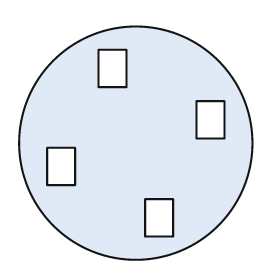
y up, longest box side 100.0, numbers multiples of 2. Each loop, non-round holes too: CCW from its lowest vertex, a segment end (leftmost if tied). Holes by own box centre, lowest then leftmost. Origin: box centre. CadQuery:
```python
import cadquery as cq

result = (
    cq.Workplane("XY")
    .moveTo(0.0, 0.0)
    .circle(50.0)
    .moveTo(4.0, -40.0)
    .lineTo(16.0, -40.0)
    .lineTo(16.0, -24.0)
    .lineTo(4.0, -24.0)
    .close()
    .moveTo(-38.0, -18.0)
    .lineTo(-26.0, -18.0)
    .lineTo(-26.0, -2.0)
    .lineTo(-38.0, -2.0)
    .close()
    .moveTo(26.0, 2.0)
    .lineTo(38.0, 2.0)
    .lineTo(38.0, 18.0)
    .lineTo(26.0, 18.0)
    .close()
    .moveTo(-16.0, 24.0)
    .lineTo(-4.0, 24.0)
    .lineTo(-4.0, 40.0)
    .lineTo(-16.0, 40.0)
    .close()
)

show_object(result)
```